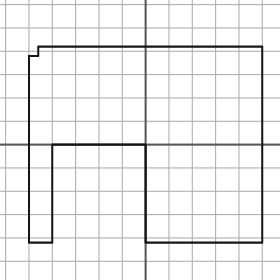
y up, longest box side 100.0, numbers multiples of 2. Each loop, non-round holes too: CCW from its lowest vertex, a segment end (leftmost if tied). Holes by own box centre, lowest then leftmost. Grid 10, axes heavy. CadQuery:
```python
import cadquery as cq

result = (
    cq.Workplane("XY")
    .moveTo(-50.0, -42.0)
    .lineTo(-40.0, -42.0)
    .lineTo(-40.0, 0.0)
    .lineTo(0.0, 0.0)
    .lineTo(0.0, -42.0)
    .lineTo(50.0, -42.0)
    .lineTo(50.0, 42.0)
    .lineTo(-46.0, 42.0)
    .lineTo(-46.0, 38.0)
    .lineTo(-50.0, 38.0)
    .close()
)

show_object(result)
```